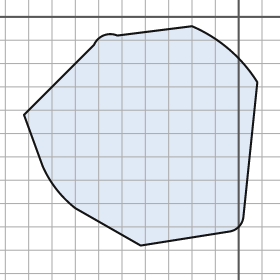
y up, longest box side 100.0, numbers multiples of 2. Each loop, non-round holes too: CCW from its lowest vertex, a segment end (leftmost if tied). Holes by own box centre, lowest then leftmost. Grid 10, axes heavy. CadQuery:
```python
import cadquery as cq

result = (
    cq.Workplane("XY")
    .moveTo(-42.0, -98.0)
    .lineTo(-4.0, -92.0)
    .threePointArc((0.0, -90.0), (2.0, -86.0))
    .lineTo(8.0, -28.0)
    .threePointArc((-4.0, -14.0), (-20.0, -4.0))
    .lineTo(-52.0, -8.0)
    .threePointArc((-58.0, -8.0), (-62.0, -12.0))
    .lineTo(-92.0, -42.0)
    .lineTo(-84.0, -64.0)
    .threePointArc((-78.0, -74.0), (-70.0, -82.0))
    .close()
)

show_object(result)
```